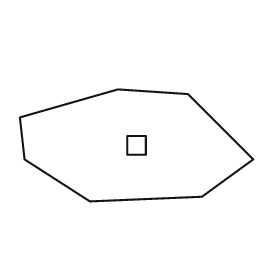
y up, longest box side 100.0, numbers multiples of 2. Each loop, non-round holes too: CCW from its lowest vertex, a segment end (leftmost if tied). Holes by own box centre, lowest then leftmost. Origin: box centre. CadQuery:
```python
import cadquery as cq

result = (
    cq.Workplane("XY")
    .moveTo(-20.0, -24.0)
    .lineTo(28.0, -22.0)
    .lineTo(50.0, -6.0)
    .lineTo(22.0, 22.0)
    .lineTo(-8.0, 24.0)
    .lineTo(-50.0, 12.0)
    .lineTo(-48.0, -6.0)
    .close()
    .moveTo(-4.0, -4.0)
    .lineTo(4.0, -4.0)
    .lineTo(4.0, 4.0)
    .lineTo(-4.0, 4.0)
    .close()
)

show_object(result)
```